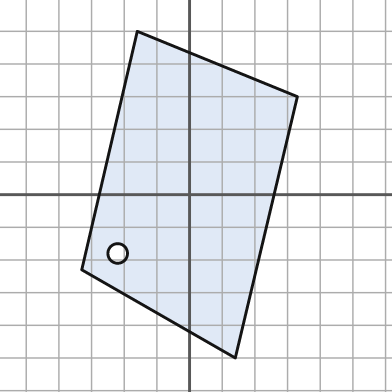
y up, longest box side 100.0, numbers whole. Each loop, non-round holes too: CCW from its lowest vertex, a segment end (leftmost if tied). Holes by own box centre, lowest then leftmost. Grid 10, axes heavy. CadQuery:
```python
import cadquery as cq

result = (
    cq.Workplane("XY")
    .moveTo(14.0, -50.0)
    .lineTo(33.0, 30.0)
    .lineTo(-16.0, 50.0)
    .lineTo(-33.0, -23.0)
    .close()
    .moveTo(-22.0, -18.0)
    .circle(3.0)
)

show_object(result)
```